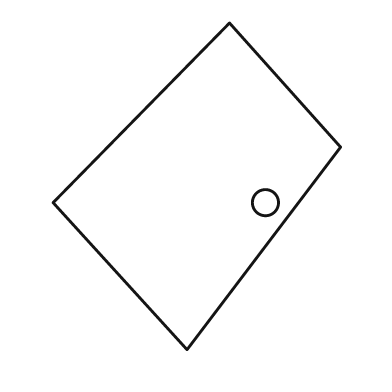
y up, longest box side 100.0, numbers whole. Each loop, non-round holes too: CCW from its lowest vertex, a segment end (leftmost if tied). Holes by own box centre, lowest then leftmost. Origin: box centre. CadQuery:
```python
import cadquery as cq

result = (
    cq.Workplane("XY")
    .moveTo(-3.0, -50.0)
    .lineTo(44.0, 12.0)
    .lineTo(10.0, 50.0)
    .lineTo(-44.0, -5.0)
    .close()
    .moveTo(21.0, -5.0)
    .circle(4.0)
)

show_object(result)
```